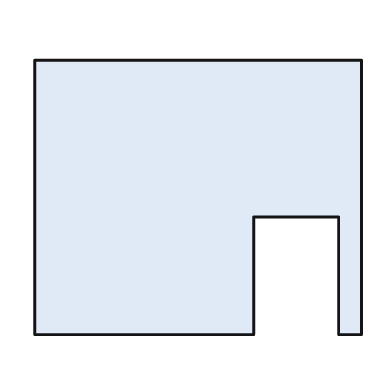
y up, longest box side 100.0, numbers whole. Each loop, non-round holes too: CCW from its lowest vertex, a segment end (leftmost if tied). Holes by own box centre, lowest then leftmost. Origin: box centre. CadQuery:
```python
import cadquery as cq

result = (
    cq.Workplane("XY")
    .moveTo(-50.0, -42.0)
    .lineTo(17.0, -42.0)
    .lineTo(17.0, -6.0)
    .lineTo(43.0, -6.0)
    .lineTo(43.0, -42.0)
    .lineTo(50.0, -42.0)
    .lineTo(50.0, 42.0)
    .lineTo(-50.0, 42.0)
    .close()
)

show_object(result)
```